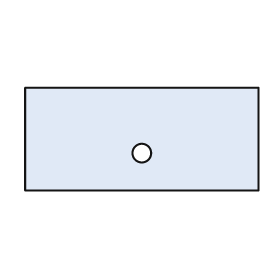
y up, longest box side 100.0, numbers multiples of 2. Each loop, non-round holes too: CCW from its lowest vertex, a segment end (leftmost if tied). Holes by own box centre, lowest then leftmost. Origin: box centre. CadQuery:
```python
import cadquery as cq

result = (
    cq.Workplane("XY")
    .moveTo(-50.0, -22.0)
    .lineTo(50.0, -22.0)
    .lineTo(50.0, 22.0)
    .lineTo(-50.0, 22.0)
    .close()
    .moveTo(0.0, -6.0)
    .circle(4.0)
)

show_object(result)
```